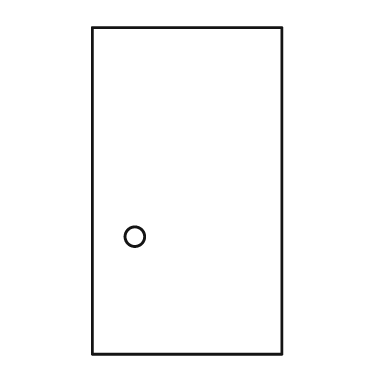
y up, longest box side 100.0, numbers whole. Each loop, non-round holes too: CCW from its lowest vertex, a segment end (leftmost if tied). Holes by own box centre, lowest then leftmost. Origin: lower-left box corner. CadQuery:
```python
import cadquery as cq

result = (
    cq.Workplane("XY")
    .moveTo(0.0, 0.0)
    .lineTo(58.0, 0.0)
    .lineTo(58.0, 100.0)
    .lineTo(0.0, 100.0)
    .close()
    .moveTo(13.0, 36.0)
    .circle(3.0)
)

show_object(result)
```